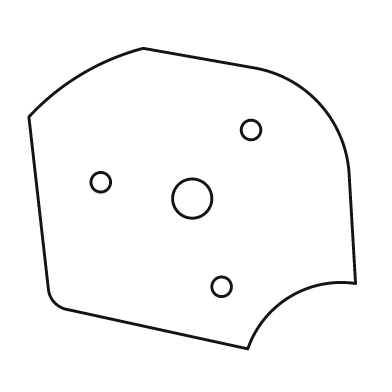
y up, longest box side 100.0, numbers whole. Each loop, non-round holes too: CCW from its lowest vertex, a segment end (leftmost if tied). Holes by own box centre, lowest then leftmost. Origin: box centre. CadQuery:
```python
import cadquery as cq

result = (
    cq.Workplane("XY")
    .moveTo(17.0, -46.0)
    .threePointArc((30.0, -30.0), (50.0, -26.0))
    .lineTo(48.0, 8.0)
    .threePointArc((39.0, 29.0), (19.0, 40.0))
    .lineTo(-15.0, 46.0)
    .threePointArc((-34.0, 38.0), (-50.0, 25.0))
    .lineTo(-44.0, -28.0)
    .threePointArc((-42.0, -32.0), (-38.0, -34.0))
    .close()
    .moveTo(9.0, -27.0)
    .circle(3.0)
    .moveTo(0.0, 0.0)
    .circle(6.0)
    .moveTo(-28.0, 5.0)
    .circle(3.0)
    .moveTo(18.0, 21.0)
    .circle(3.0)
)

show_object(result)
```